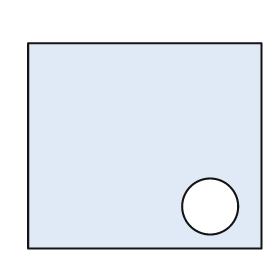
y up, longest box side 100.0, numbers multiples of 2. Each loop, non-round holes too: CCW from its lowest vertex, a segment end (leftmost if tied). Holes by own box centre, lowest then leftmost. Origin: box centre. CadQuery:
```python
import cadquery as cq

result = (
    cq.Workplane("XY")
    .moveTo(-50.0, -44.0)
    .lineTo(50.0, -44.0)
    .lineTo(50.0, 44.0)
    .lineTo(-50.0, 44.0)
    .close()
    .moveTo(28.0, -26.0)
    .circle(12.0)
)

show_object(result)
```